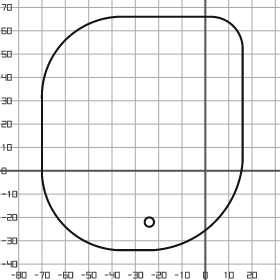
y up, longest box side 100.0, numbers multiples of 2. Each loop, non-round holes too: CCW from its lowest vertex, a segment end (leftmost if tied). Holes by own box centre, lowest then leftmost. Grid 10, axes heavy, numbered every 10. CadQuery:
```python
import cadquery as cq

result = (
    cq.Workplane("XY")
    .moveTo(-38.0, -34.0)
    .lineTo(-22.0, -34.0)
    .threePointArc((4.0, -22.0), (16.0, 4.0))
    .lineTo(16.0, 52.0)
    .threePointArc((12.0, 62.0), (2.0, 66.0))
    .lineTo(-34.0, 66.0)
    .threePointArc((-60.0, 56.0), (-70.0, 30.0))
    .lineTo(-70.0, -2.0)
    .threePointArc((-60.0, -24.0), (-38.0, -34.0))
    .close()
    .moveTo(-24.0, -22.0)
    .circle(2.0)
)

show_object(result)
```